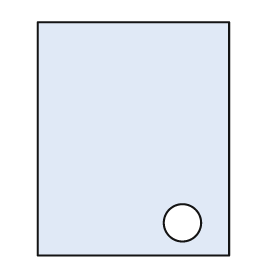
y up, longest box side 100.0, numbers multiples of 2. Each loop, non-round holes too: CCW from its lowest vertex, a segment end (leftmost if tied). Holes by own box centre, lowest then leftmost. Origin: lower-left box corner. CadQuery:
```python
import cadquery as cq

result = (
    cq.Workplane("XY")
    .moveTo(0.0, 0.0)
    .lineTo(82.0, 0.0)
    .lineTo(82.0, 100.0)
    .lineTo(0.0, 100.0)
    .close()
    .moveTo(62.0, 14.0)
    .circle(8.0)
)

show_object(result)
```